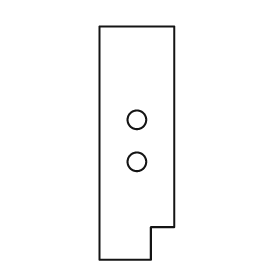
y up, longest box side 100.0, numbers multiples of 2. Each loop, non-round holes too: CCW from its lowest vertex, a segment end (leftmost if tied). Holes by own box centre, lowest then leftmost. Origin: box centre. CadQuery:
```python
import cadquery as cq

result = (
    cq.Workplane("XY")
    .moveTo(-16.0, -50.0)
    .lineTo(6.0, -50.0)
    .lineTo(6.0, -36.0)
    .lineTo(16.0, -36.0)
    .lineTo(16.0, 50.0)
    .lineTo(-16.0, 50.0)
    .close()
    .moveTo(0.0, -8.0)
    .circle(4.0)
    .moveTo(0.0, 10.0)
    .circle(4.0)
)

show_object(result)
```